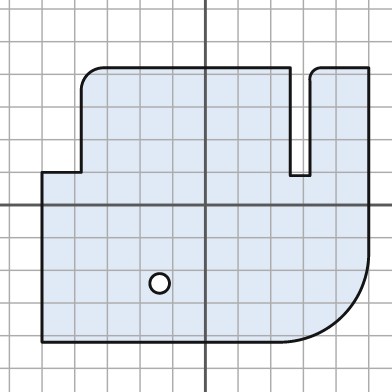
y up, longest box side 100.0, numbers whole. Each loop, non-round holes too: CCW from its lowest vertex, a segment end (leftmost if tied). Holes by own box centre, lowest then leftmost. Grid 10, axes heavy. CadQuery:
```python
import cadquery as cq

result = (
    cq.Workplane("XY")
    .moveTo(-50.0, -42.0)
    .lineTo(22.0, -42.0)
    .threePointArc((42.0, -34.0), (50.0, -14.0))
    .lineTo(50.0, 42.0)
    .lineTo(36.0, 42.0)
    .threePointArc((33.0, 41.0), (32.0, 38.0))
    .lineTo(32.0, 9.0)
    .lineTo(26.0, 9.0)
    .lineTo(26.0, 42.0)
    .lineTo(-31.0, 42.0)
    .threePointArc((-36.0, 40.0), (-38.0, 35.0))
    .lineTo(-38.0, 10.0)
    .lineTo(-50.0, 10.0)
    .close()
    .moveTo(-14.0, -24.0)
    .circle(3.0)
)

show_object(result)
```